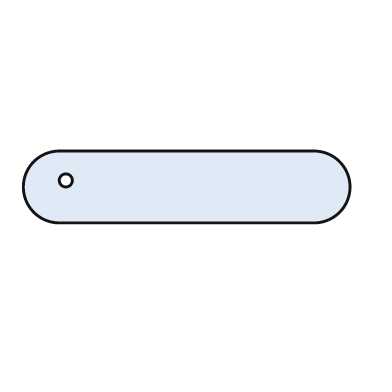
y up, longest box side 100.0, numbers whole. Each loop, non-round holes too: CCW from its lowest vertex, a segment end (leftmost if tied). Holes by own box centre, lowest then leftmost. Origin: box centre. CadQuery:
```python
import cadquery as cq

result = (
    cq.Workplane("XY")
    .moveTo(-39.0, -11.0)
    .lineTo(39.0, -11.0)
    .threePointArc((50.0, 0.0), (39.0, 11.0))
    .lineTo(-39.0, 11.0)
    .threePointArc((-50.0, 0.0), (-39.0, -11.0))
    .close()
    .moveTo(-37.0, 2.0)
    .circle(2.0)
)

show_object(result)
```